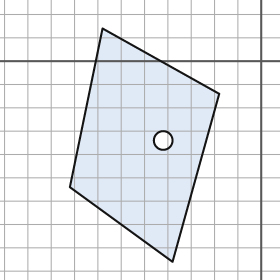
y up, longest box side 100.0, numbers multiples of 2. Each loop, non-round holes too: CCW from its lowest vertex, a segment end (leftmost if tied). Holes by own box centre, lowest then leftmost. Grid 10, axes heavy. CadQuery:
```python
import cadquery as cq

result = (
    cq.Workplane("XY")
    .moveTo(-38.0, -86.0)
    .lineTo(-18.0, -14.0)
    .lineTo(-68.0, 14.0)
    .lineTo(-82.0, -54.0)
    .close()
    .moveTo(-42.0, -34.0)
    .circle(4.0)
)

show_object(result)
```